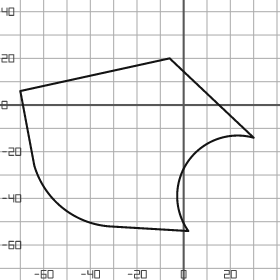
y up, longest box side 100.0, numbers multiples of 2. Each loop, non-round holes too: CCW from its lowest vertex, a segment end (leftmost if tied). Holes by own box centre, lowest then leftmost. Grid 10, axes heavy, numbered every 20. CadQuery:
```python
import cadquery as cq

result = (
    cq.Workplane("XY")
    .moveTo(2.0, -54.0)
    .threePointArc((2.0, -24.0), (30.0, -14.0))
    .lineTo(-6.0, 20.0)
    .lineTo(-70.0, 6.0)
    .lineTo(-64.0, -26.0)
    .threePointArc((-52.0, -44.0), (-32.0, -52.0))
    .close()
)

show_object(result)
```